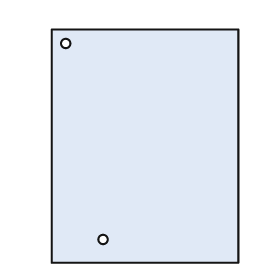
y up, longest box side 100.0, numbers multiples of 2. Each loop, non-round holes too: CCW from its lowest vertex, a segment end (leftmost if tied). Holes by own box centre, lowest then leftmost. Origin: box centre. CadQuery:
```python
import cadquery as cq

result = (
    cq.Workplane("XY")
    .moveTo(-40.0, -50.0)
    .lineTo(40.0, -50.0)
    .lineTo(40.0, 50.0)
    .lineTo(-40.0, 50.0)
    .close()
    .moveTo(-18.0, -40.0)
    .circle(2.0)
    .moveTo(-34.0, 44.0)
    .circle(2.0)
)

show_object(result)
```